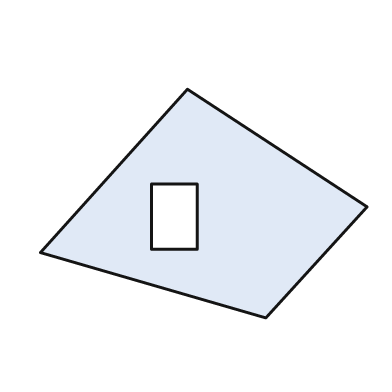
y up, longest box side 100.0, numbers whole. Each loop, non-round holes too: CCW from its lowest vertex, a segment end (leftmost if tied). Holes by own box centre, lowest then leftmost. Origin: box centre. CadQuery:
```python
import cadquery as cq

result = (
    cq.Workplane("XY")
    .moveTo(19.0, -35.0)
    .lineTo(50.0, -1.0)
    .lineTo(-5.0, 35.0)
    .lineTo(-50.0, -15.0)
    .close()
    .moveTo(-16.0, -14.0)
    .lineTo(-2.0, -14.0)
    .lineTo(-2.0, 6.0)
    .lineTo(-16.0, 6.0)
    .close()
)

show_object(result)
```